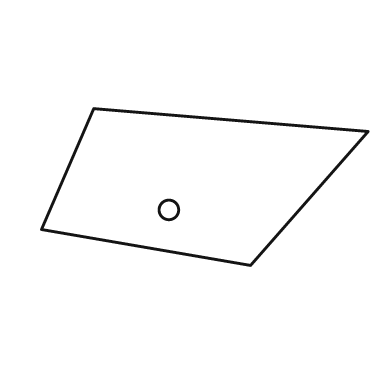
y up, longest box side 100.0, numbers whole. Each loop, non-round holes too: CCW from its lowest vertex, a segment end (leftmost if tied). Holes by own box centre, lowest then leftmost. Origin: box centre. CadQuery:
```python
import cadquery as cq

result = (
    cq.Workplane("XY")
    .moveTo(14.0, -24.0)
    .lineTo(50.0, 17.0)
    .lineTo(-34.0, 24.0)
    .lineTo(-50.0, -13.0)
    .close()
    .moveTo(-11.0, -7.0)
    .circle(3.0)
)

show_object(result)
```